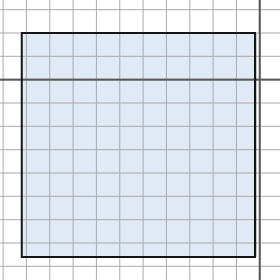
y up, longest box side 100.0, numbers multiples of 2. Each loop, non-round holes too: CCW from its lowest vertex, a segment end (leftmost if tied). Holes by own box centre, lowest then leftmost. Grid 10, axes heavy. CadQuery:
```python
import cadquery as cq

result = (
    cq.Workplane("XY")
    .moveTo(-102.0, -76.0)
    .lineTo(-2.0, -76.0)
    .lineTo(-2.0, 20.0)
    .lineTo(-102.0, 20.0)
    .close()
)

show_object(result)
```